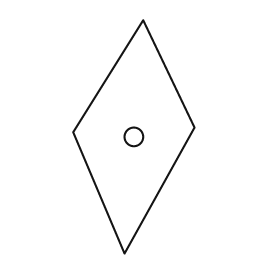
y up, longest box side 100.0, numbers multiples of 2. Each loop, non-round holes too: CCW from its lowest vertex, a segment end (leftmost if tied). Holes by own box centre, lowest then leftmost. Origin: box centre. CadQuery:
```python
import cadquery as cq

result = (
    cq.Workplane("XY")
    .moveTo(-4.0, -50.0)
    .lineTo(26.0, 4.0)
    .lineTo(4.0, 50.0)
    .lineTo(-26.0, 2.0)
    .close()
    .moveTo(0.0, 0.0)
    .circle(4.0)
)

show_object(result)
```